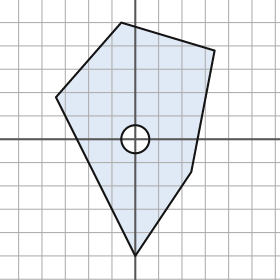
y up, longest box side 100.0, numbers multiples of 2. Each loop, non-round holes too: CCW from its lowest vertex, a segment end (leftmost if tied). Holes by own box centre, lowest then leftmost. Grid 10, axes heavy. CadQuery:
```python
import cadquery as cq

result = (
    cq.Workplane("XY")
    .moveTo(0.0, -50.0)
    .lineTo(24.0, -14.0)
    .lineTo(34.0, 38.0)
    .lineTo(-6.0, 50.0)
    .lineTo(-34.0, 18.0)
    .close()
    .moveTo(0.0, 0.0)
    .circle(6.0)
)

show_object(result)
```